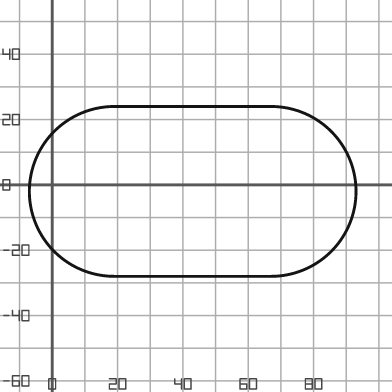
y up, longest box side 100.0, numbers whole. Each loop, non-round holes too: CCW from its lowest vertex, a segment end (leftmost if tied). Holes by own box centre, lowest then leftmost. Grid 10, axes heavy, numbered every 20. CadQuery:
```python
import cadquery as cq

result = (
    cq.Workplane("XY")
    .moveTo(19.0, -28.0)
    .lineTo(67.0, -28.0)
    .threePointArc((93.0, -2.0), (67.0, 24.0))
    .lineTo(19.0, 24.0)
    .threePointArc((-7.0, -2.0), (19.0, -28.0))
    .close()
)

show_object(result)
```